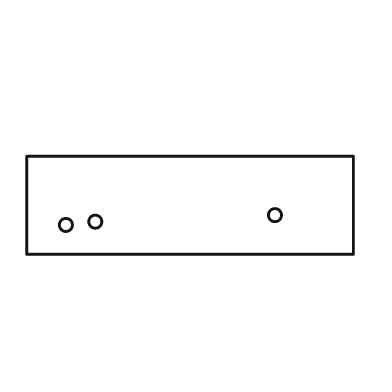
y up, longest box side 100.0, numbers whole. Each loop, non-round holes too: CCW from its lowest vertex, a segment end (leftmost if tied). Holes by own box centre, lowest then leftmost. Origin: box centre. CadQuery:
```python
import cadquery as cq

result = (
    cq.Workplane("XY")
    .moveTo(-50.0, -15.0)
    .lineTo(50.0, -15.0)
    .lineTo(50.0, 15.0)
    .lineTo(-50.0, 15.0)
    .close()
    .moveTo(-38.0, -6.0)
    .circle(2.0)
    .moveTo(-29.0, -5.0)
    .circle(2.0)
    .moveTo(26.0, -3.0)
    .circle(2.0)
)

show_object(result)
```